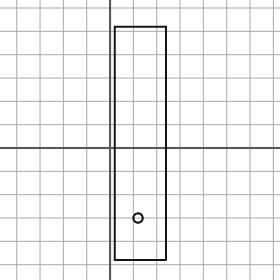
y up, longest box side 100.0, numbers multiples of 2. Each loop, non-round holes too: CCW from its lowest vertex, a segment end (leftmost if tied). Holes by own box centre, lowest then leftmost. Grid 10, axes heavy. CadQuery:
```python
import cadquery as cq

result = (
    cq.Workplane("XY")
    .moveTo(2.0, -48.0)
    .lineTo(24.0, -48.0)
    .lineTo(24.0, 52.0)
    .lineTo(2.0, 52.0)
    .close()
    .moveTo(12.0, -30.0)
    .circle(2.0)
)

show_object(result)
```